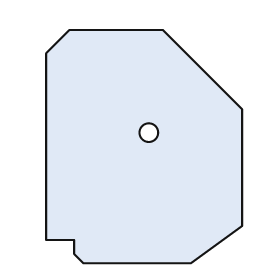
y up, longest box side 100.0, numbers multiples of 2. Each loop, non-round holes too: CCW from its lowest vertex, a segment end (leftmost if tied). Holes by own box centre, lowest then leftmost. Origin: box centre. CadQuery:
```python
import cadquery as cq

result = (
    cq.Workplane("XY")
    .moveTo(-26.0, -50.0)
    .lineTo(20.0, -50.0)
    .lineTo(42.0, -34.0)
    .lineTo(42.0, 16.0)
    .lineTo(8.0, 50.0)
    .lineTo(-32.0, 50.0)
    .lineTo(-42.0, 40.0)
    .lineTo(-42.0, -40.0)
    .lineTo(-30.0, -40.0)
    .lineTo(-30.0, -46.0)
    .close()
    .moveTo(2.0, 6.0)
    .circle(4.0)
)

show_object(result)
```